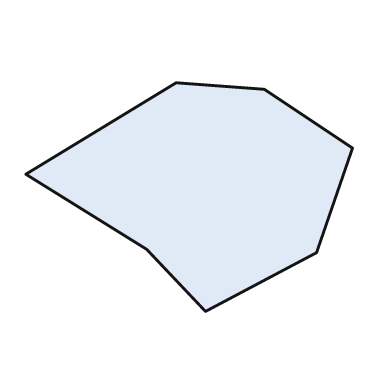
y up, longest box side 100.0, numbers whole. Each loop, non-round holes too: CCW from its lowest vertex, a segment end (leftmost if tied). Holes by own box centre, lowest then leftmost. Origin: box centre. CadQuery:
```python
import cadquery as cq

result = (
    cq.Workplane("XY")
    .moveTo(5.0, -35.0)
    .lineTo(39.0, -17.0)
    .lineTo(50.0, 15.0)
    .lineTo(23.0, 33.0)
    .lineTo(-4.0, 35.0)
    .lineTo(-50.0, 7.0)
    .lineTo(-13.0, -16.0)
    .close()
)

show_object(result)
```